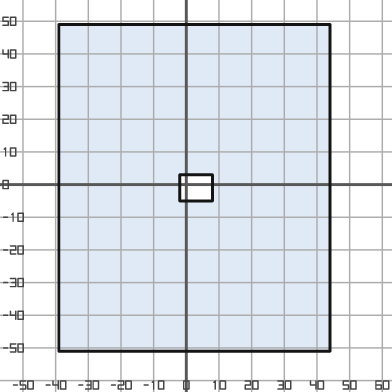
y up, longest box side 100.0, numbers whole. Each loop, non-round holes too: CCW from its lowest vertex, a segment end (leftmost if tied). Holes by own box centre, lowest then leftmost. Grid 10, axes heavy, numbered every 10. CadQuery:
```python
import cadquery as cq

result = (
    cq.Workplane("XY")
    .moveTo(-39.0, -51.0)
    .lineTo(44.0, -51.0)
    .lineTo(44.0, 49.0)
    .lineTo(-39.0, 49.0)
    .close()
    .moveTo(-2.0, -5.0)
    .lineTo(8.0, -5.0)
    .lineTo(8.0, 3.0)
    .lineTo(-2.0, 3.0)
    .close()
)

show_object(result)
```